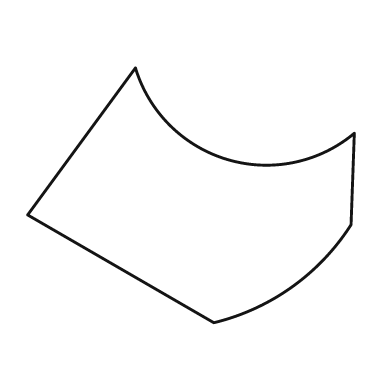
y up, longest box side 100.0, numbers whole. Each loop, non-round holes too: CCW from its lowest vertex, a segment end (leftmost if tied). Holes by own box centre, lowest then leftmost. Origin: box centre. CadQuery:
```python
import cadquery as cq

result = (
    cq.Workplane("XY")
    .moveTo(7.0, -39.0)
    .threePointArc((31.0, -28.0), (49.0, -9.0))
    .lineTo(50.0, 19.0)
    .threePointArc((11.0, 11.0), (-17.0, 39.0))
    .lineTo(-50.0, -6.0)
    .close()
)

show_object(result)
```